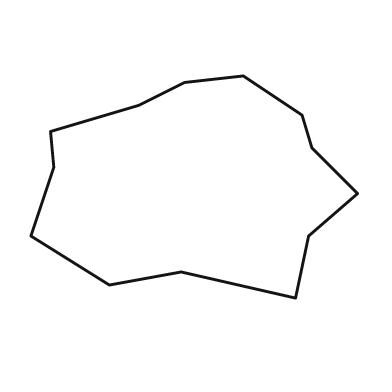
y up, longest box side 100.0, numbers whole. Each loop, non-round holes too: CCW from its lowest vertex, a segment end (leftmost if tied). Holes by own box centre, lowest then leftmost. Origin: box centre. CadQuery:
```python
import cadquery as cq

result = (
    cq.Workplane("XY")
    .moveTo(31.0, -34.0)
    .lineTo(35.0, -15.0)
    .lineTo(50.0, -2.0)
    .lineTo(36.0, 12.0)
    .lineTo(33.0, 22.0)
    .lineTo(15.0, 34.0)
    .lineTo(-3.0, 32.0)
    .lineTo(-17.0, 25.0)
    .lineTo(-44.0, 17.0)
    .lineTo(-43.0, 6.0)
    .lineTo(-50.0, -15.0)
    .lineTo(-26.0, -30.0)
    .lineTo(-4.0, -26.0)
    .close()
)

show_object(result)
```